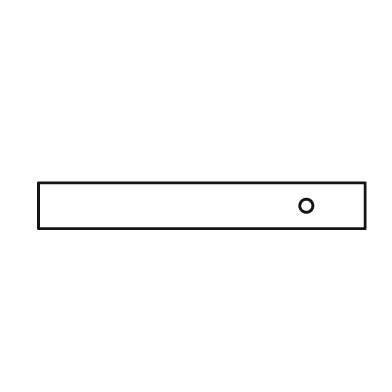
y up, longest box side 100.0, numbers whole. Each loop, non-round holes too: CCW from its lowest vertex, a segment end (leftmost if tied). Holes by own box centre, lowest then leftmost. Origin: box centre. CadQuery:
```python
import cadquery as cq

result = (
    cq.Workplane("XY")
    .moveTo(-50.0, -7.0)
    .lineTo(50.0, -7.0)
    .lineTo(50.0, 7.0)
    .lineTo(-50.0, 7.0)
    .close()
    .moveTo(32.0, 0.0)
    .circle(2.0)
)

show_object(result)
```